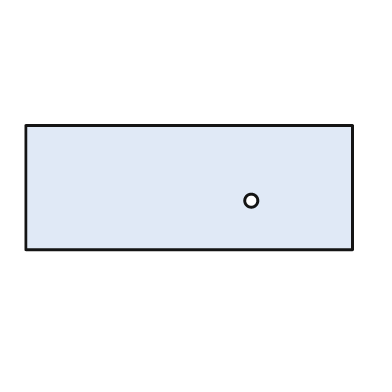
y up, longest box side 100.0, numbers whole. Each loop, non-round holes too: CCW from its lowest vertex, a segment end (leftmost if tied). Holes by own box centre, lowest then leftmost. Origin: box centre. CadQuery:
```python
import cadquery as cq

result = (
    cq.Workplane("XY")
    .moveTo(-50.0, -19.0)
    .lineTo(50.0, -19.0)
    .lineTo(50.0, 19.0)
    .lineTo(-50.0, 19.0)
    .close()
    .moveTo(19.0, -4.0)
    .circle(2.0)
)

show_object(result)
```